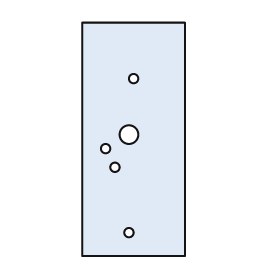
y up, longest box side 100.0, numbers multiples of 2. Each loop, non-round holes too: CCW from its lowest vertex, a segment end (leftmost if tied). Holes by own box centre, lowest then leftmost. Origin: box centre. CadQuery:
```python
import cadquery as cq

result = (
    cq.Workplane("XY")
    .moveTo(-22.0, -50.0)
    .lineTo(22.0, -50.0)
    .lineTo(22.0, 50.0)
    .lineTo(-22.0, 50.0)
    .close()
    .moveTo(-2.0, -40.0)
    .circle(2.0)
    .moveTo(-8.0, -12.0)
    .circle(2.0)
    .moveTo(-12.0, -4.0)
    .circle(2.0)
    .moveTo(-2.0, 2.0)
    .circle(4.0)
    .moveTo(0.0, 26.0)
    .circle(2.0)
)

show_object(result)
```